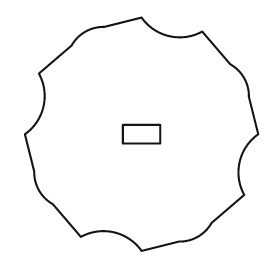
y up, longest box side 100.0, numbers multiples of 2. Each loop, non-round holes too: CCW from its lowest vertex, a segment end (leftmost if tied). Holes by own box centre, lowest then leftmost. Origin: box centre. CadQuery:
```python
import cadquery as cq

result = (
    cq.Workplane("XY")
    .moveTo(0.0, -50.0)
    .lineTo(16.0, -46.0)
    .threePointArc((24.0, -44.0), (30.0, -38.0))
    .lineTo(44.0, -26.0)
    .threePointArc((42.0, -12.0), (50.0, 0.0))
    .lineTo(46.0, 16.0)
    .threePointArc((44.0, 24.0), (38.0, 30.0))
    .lineTo(26.0, 44.0)
    .threePointArc((12.0, 42.0), (0.0, 50.0))
    .lineTo(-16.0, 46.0)
    .threePointArc((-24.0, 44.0), (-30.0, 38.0))
    .lineTo(-44.0, 26.0)
    .threePointArc((-42.0, 12.0), (-50.0, 0.0))
    .lineTo(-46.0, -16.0)
    .threePointArc((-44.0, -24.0), (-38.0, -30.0))
    .lineTo(-26.0, -44.0)
    .threePointArc((-12.0, -42.0), (0.0, -50.0))
    .close()
    .moveTo(-8.0, -4.0)
    .lineTo(8.0, -4.0)
    .lineTo(8.0, 4.0)
    .lineTo(-8.0, 4.0)
    .close()
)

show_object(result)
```